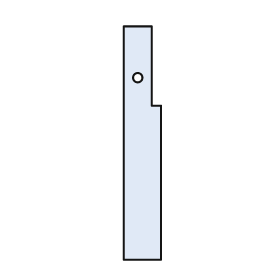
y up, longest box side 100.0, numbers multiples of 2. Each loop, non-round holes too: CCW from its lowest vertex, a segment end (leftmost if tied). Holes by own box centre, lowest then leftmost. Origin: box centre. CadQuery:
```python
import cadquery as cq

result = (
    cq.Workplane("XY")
    .moveTo(-8.0, -50.0)
    .lineTo(8.0, -50.0)
    .lineTo(8.0, 16.0)
    .lineTo(4.0, 16.0)
    .lineTo(4.0, 50.0)
    .lineTo(-8.0, 50.0)
    .close()
    .moveTo(-2.0, 28.0)
    .circle(2.0)
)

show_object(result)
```